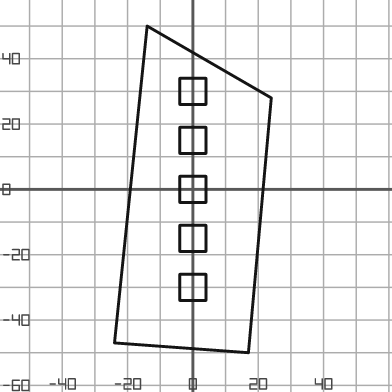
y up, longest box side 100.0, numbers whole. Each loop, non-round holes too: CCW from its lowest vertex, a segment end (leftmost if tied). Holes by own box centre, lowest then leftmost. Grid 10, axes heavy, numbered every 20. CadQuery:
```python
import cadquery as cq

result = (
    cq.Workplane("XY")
    .moveTo(17.0, -50.0)
    .lineTo(24.0, 28.0)
    .lineTo(-14.0, 50.0)
    .lineTo(-24.0, -47.0)
    .close()
    .moveTo(-4.0, -34.0)
    .lineTo(4.0, -34.0)
    .lineTo(4.0, -26.0)
    .lineTo(-4.0, -26.0)
    .close()
    .moveTo(-4.0, -19.0)
    .lineTo(4.0, -19.0)
    .lineTo(4.0, -11.0)
    .lineTo(-4.0, -11.0)
    .close()
    .moveTo(-4.0, -4.0)
    .lineTo(4.0, -4.0)
    .lineTo(4.0, 4.0)
    .lineTo(-4.0, 4.0)
    .close()
    .moveTo(-4.0, 11.0)
    .lineTo(4.0, 11.0)
    .lineTo(4.0, 19.0)
    .lineTo(-4.0, 19.0)
    .close()
    .moveTo(-4.0, 26.0)
    .lineTo(4.0, 26.0)
    .lineTo(4.0, 34.0)
    .lineTo(-4.0, 34.0)
    .close()
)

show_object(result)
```